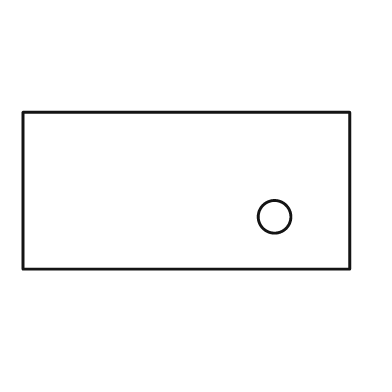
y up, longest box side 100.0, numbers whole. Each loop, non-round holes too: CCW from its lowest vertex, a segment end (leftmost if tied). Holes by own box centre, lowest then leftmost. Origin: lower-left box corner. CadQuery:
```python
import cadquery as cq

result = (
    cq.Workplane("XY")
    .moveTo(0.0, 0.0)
    .lineTo(100.0, 0.0)
    .lineTo(100.0, 48.0)
    .lineTo(0.0, 48.0)
    .close()
    .moveTo(77.0, 16.0)
    .circle(5.0)
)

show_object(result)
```